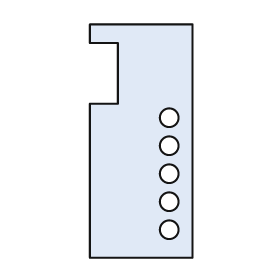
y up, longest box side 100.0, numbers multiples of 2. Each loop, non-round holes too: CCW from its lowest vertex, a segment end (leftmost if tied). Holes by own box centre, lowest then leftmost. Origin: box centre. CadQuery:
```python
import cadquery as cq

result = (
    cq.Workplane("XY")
    .moveTo(-22.0, -50.0)
    .lineTo(22.0, -50.0)
    .lineTo(22.0, 50.0)
    .lineTo(-22.0, 50.0)
    .lineTo(-22.0, 42.0)
    .lineTo(-10.0, 42.0)
    .lineTo(-10.0, 16.0)
    .lineTo(-22.0, 16.0)
    .close()
    .moveTo(12.0, -38.0)
    .circle(4.0)
    .moveTo(12.0, -26.0)
    .circle(4.0)
    .moveTo(12.0, -14.0)
    .circle(4.0)
    .moveTo(12.0, -2.0)
    .circle(4.0)
    .moveTo(12.0, 10.0)
    .circle(4.0)
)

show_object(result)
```